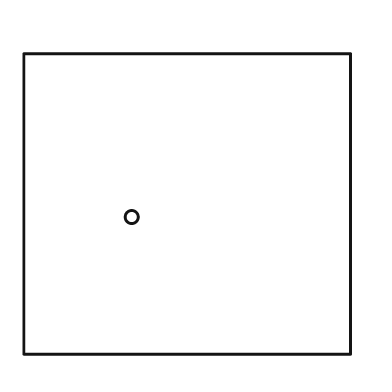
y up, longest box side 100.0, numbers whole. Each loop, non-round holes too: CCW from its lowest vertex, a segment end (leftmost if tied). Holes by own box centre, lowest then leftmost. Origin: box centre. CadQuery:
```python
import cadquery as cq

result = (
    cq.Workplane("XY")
    .moveTo(-50.0, -46.0)
    .lineTo(50.0, -46.0)
    .lineTo(50.0, 46.0)
    .lineTo(-50.0, 46.0)
    .close()
    .moveTo(-17.0, -4.0)
    .circle(2.0)
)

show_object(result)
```